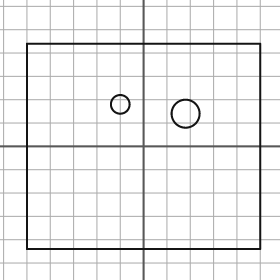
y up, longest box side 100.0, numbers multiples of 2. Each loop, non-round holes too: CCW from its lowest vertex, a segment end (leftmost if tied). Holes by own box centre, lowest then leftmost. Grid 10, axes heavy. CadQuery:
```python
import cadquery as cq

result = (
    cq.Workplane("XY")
    .moveTo(-50.0, -44.0)
    .lineTo(50.0, -44.0)
    .lineTo(50.0, 44.0)
    .lineTo(-50.0, 44.0)
    .close()
    .moveTo(18.0, 14.0)
    .circle(6.0)
    .moveTo(-10.0, 18.0)
    .circle(4.0)
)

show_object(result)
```